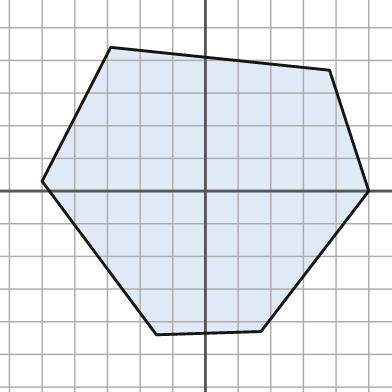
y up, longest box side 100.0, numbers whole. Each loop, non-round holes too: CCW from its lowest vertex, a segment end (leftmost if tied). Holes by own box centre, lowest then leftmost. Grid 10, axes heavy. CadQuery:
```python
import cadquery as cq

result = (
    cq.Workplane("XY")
    .moveTo(-15.0, -44.0)
    .lineTo(17.0, -43.0)
    .lineTo(50.0, 0.0)
    .lineTo(38.0, 37.0)
    .lineTo(-29.0, 44.0)
    .lineTo(-50.0, 3.0)
    .close()
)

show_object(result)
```